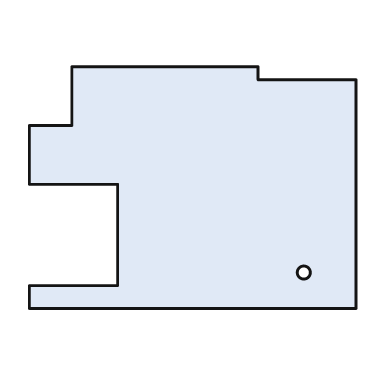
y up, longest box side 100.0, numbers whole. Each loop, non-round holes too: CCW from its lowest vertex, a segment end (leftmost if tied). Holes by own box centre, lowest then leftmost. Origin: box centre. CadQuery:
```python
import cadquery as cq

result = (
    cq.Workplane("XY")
    .moveTo(-50.0, -37.0)
    .lineTo(50.0, -37.0)
    .lineTo(50.0, 33.0)
    .lineTo(20.0, 33.0)
    .lineTo(20.0, 37.0)
    .lineTo(-37.0, 37.0)
    .lineTo(-37.0, 19.0)
    .lineTo(-50.0, 19.0)
    .lineTo(-50.0, 1.0)
    .lineTo(-23.0, 1.0)
    .lineTo(-23.0, -30.0)
    .lineTo(-50.0, -30.0)
    .close()
    .moveTo(34.0, -26.0)
    .circle(2.0)
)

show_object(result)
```